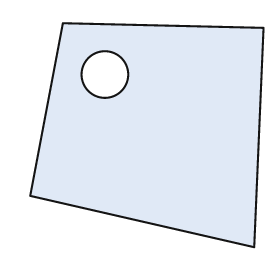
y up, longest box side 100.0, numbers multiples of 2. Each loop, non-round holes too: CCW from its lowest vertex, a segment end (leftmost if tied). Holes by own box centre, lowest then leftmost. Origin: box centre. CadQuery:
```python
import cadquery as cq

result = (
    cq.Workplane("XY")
    .moveTo(46.0, -48.0)
    .lineTo(50.0, 46.0)
    .lineTo(-36.0, 48.0)
    .lineTo(-50.0, -26.0)
    .close()
    .moveTo(-18.0, 26.0)
    .circle(10.0)
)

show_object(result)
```